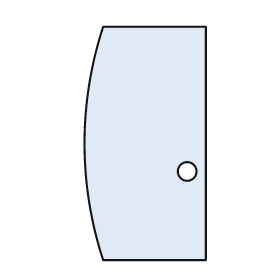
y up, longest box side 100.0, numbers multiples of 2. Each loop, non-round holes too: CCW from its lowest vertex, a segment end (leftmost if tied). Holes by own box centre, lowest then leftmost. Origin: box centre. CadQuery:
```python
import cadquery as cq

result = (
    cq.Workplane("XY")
    .moveTo(-18.0, -50.0)
    .lineTo(26.0, -50.0)
    .lineTo(26.0, 50.0)
    .lineTo(-18.0, 50.0)
    .threePointArc((-26.0, 0.0), (-18.0, -50.0))
    .close()
    .moveTo(18.0, -12.0)
    .circle(4.0)
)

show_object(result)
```